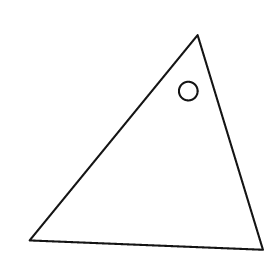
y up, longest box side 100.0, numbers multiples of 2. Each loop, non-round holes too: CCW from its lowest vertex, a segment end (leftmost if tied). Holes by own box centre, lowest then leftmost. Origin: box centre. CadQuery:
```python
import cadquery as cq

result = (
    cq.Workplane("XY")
    .moveTo(50.0, -46.0)
    .lineTo(22.0, 46.0)
    .lineTo(-50.0, -42.0)
    .close()
    .moveTo(18.0, 22.0)
    .circle(4.0)
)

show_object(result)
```